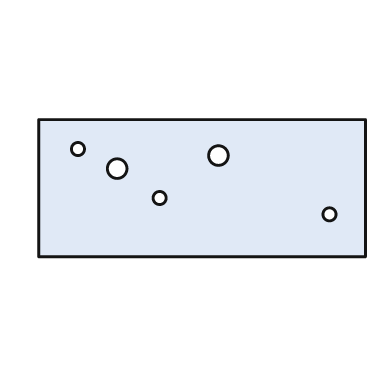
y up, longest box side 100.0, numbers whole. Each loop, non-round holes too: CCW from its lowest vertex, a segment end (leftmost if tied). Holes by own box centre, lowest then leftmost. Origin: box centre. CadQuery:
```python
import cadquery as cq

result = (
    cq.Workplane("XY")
    .moveTo(-50.0, -21.0)
    .lineTo(50.0, -21.0)
    .lineTo(50.0, 21.0)
    .lineTo(-50.0, 21.0)
    .close()
    .moveTo(39.0, -8.0)
    .circle(2.0)
    .moveTo(-13.0, -3.0)
    .circle(2.0)
    .moveTo(-26.0, 6.0)
    .circle(3.0)
    .moveTo(5.0, 10.0)
    .circle(3.0)
    .moveTo(-38.0, 12.0)
    .circle(2.0)
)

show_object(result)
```